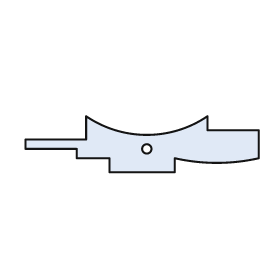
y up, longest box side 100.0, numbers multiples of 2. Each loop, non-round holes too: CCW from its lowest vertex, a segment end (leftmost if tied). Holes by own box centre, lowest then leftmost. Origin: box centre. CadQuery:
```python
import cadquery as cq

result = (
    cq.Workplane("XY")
    .moveTo(-14.0, -12.0)
    .lineTo(14.0, -12.0)
    .lineTo(14.0, -6.0)
    .threePointArc((32.0, -8.0), (50.0, -6.0))
    .lineTo(50.0, 6.0)
    .lineTo(28.0, 6.0)
    .lineTo(28.0, 12.0)
    .threePointArc((2.0, 4.0), (-24.0, 12.0))
    .lineTo(-24.0, 2.0)
    .lineTo(-50.0, 2.0)
    .lineTo(-50.0, -2.0)
    .lineTo(-28.0, -2.0)
    .lineTo(-28.0, -6.0)
    .lineTo(-14.0, -6.0)
    .close()
    .moveTo(2.0, -2.0)
    .circle(2.0)
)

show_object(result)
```